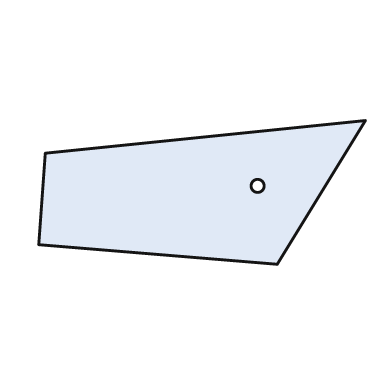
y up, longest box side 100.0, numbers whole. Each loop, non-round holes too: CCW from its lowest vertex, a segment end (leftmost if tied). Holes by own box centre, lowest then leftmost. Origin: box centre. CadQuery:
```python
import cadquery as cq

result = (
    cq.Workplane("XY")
    .moveTo(23.0, -22.0)
    .lineTo(50.0, 22.0)
    .lineTo(-48.0, 12.0)
    .lineTo(-50.0, -16.0)
    .close()
    .moveTo(17.0, 2.0)
    .circle(2.0)
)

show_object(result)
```